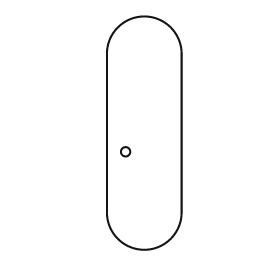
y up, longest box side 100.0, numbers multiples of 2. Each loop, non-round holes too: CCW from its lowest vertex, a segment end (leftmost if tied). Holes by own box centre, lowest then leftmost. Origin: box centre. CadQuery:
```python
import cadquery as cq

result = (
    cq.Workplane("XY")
    .moveTo(-16.0, -34.0)
    .threePointArc((0.0, -50.0), (16.0, -34.0))
    .lineTo(16.0, 34.0)
    .threePointArc((0.0, 50.0), (-16.0, 34.0))
    .close()
    .moveTo(-8.0, -8.0)
    .circle(2.0)
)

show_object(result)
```